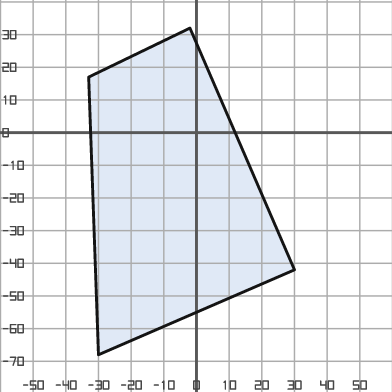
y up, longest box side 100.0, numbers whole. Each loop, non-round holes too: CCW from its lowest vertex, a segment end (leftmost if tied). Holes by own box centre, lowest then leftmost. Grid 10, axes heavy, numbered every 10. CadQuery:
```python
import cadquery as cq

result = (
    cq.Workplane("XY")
    .moveTo(-30.0, -68.0)
    .lineTo(30.0, -42.0)
    .lineTo(-2.0, 32.0)
    .lineTo(-33.0, 17.0)
    .close()
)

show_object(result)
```